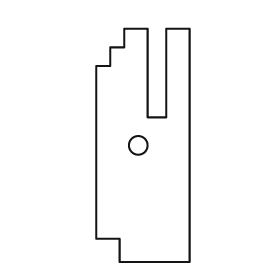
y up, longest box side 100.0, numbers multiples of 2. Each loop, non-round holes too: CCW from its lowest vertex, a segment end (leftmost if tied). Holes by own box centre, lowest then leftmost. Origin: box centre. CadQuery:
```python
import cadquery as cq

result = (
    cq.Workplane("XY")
    .moveTo(-10.0, -50.0)
    .lineTo(20.0, -50.0)
    .lineTo(20.0, 50.0)
    .lineTo(10.0, 50.0)
    .lineTo(10.0, 12.0)
    .lineTo(2.0, 12.0)
    .lineTo(2.0, 50.0)
    .lineTo(-8.0, 50.0)
    .lineTo(-8.0, 42.0)
    .lineTo(-14.0, 42.0)
    .lineTo(-14.0, 34.0)
    .lineTo(-20.0, 34.0)
    .lineTo(-20.0, -40.0)
    .lineTo(-10.0, -40.0)
    .close()
    .moveTo(-2.0, 0.0)
    .circle(4.0)
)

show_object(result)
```